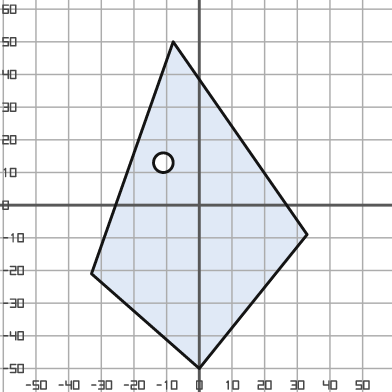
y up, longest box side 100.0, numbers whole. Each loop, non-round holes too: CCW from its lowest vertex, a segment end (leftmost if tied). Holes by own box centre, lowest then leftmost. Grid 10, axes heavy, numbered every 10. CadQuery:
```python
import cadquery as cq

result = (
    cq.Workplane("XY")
    .moveTo(0.0, -50.0)
    .lineTo(33.0, -9.0)
    .lineTo(-8.0, 50.0)
    .lineTo(-33.0, -21.0)
    .close()
    .moveTo(-11.0, 13.0)
    .circle(3.0)
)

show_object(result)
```